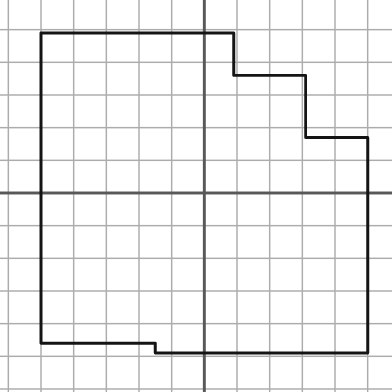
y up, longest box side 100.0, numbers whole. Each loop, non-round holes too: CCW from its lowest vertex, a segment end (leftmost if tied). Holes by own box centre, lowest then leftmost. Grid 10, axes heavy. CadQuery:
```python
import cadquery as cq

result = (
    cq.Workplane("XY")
    .moveTo(-15.0, -49.0)
    .lineTo(50.0, -49.0)
    .lineTo(50.0, 17.0)
    .lineTo(31.0, 17.0)
    .lineTo(31.0, 36.0)
    .lineTo(9.0, 36.0)
    .lineTo(9.0, 49.0)
    .lineTo(-50.0, 49.0)
    .lineTo(-50.0, -46.0)
    .lineTo(-15.0, -46.0)
    .close()
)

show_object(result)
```